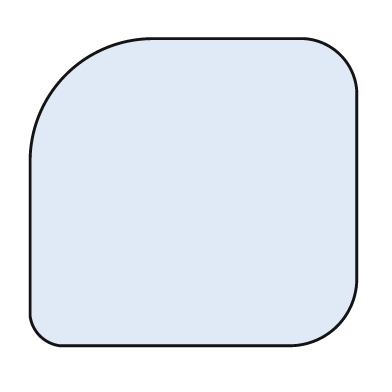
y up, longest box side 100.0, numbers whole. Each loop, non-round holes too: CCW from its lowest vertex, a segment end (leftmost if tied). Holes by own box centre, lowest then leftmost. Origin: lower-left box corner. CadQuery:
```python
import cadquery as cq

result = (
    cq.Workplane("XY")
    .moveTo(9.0, 0.0)
    .lineTo(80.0, 0.0)
    .threePointArc((94.0, 6.0), (100.0, 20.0))
    .lineTo(100.0, 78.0)
    .threePointArc((95.0, 89.0), (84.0, 94.0))
    .lineTo(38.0, 94.0)
    .threePointArc((11.0, 83.0), (0.0, 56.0))
    .lineTo(0.0, 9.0)
    .threePointArc((3.0, 3.0), (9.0, 0.0))
    .close()
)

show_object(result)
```